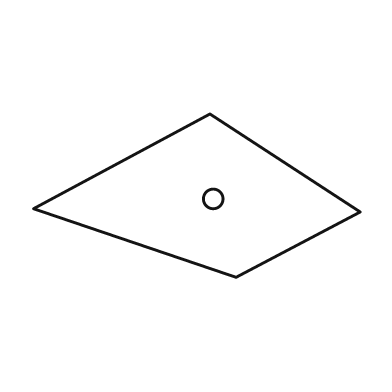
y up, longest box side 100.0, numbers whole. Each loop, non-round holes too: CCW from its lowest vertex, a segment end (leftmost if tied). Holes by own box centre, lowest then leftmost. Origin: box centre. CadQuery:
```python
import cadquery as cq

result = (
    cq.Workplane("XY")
    .moveTo(12.0, -25.0)
    .lineTo(50.0, -5.0)
    .lineTo(4.0, 25.0)
    .lineTo(-50.0, -4.0)
    .close()
    .moveTo(5.0, -1.0)
    .circle(3.0)
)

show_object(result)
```